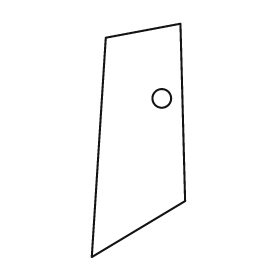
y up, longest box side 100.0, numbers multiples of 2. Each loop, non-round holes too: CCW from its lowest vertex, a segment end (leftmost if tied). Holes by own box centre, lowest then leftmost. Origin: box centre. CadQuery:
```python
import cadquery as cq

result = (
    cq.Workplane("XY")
    .moveTo(-20.0, -50.0)
    .lineTo(20.0, -26.0)
    .lineTo(18.0, 50.0)
    .lineTo(-14.0, 44.0)
    .close()
    .moveTo(10.0, 18.0)
    .circle(4.0)
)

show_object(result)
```